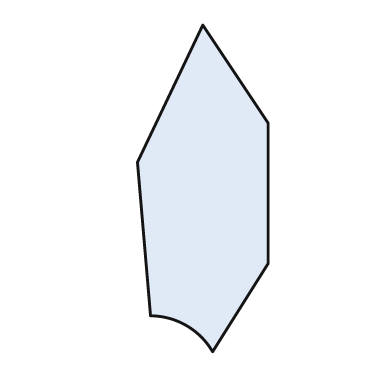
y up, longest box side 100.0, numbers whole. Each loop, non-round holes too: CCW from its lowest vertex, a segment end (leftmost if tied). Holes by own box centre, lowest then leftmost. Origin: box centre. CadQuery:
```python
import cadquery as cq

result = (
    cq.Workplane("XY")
    .moveTo(3.0, -50.0)
    .lineTo(20.0, -23.0)
    .lineTo(20.0, 20.0)
    .lineTo(0.0, 50.0)
    .lineTo(-20.0, 8.0)
    .lineTo(-16.0, -39.0)
    .threePointArc((-5.0, -42.0), (3.0, -50.0))
    .close()
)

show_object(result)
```